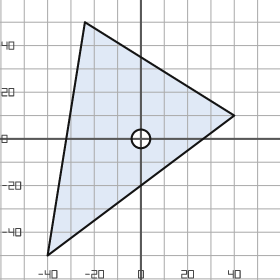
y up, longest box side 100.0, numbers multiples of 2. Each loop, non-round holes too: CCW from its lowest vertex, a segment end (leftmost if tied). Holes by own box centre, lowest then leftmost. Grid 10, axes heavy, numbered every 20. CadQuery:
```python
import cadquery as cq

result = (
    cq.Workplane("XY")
    .moveTo(-40.0, -50.0)
    .lineTo(40.0, 10.0)
    .lineTo(-24.0, 50.0)
    .close()
    .moveTo(0.0, 0.0)
    .circle(4.0)
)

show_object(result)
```